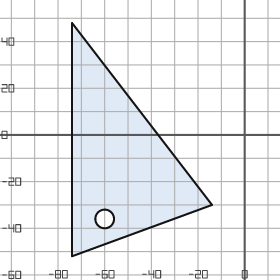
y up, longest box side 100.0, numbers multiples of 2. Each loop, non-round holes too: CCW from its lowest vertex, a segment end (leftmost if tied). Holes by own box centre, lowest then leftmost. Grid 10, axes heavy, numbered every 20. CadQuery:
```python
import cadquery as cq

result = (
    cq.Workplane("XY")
    .moveTo(-74.0, -52.0)
    .lineTo(-14.0, -30.0)
    .lineTo(-74.0, 48.0)
    .close()
    .moveTo(-60.0, -36.0)
    .circle(4.0)
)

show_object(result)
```